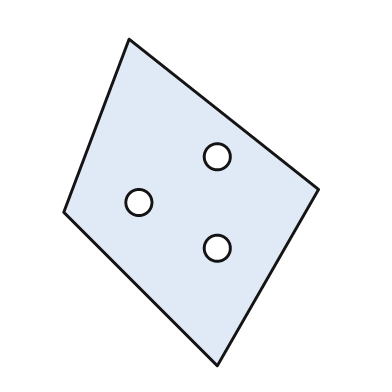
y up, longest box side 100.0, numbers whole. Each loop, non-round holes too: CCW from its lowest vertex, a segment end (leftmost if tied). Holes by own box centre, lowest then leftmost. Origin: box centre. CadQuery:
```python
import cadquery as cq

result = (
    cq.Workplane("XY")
    .moveTo(8.0, -50.0)
    .lineTo(39.0, 4.0)
    .lineTo(-19.0, 50.0)
    .lineTo(-39.0, -3.0)
    .close()
    .moveTo(8.0, -14.0)
    .circle(4.0)
    .moveTo(-16.0, 0.0)
    .circle(4.0)
    .moveTo(8.0, 14.0)
    .circle(4.0)
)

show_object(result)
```